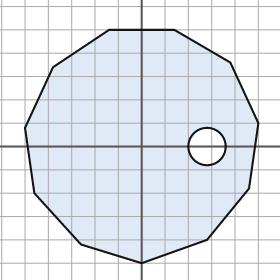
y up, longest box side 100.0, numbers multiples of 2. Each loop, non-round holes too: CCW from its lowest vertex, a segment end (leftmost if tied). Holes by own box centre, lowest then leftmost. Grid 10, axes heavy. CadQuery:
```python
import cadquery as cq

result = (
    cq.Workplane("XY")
    .moveTo(0.0, -50.0)
    .lineTo(28.0, -40.0)
    .lineTo(46.0, -18.0)
    .lineTo(50.0, 10.0)
    .lineTo(38.0, 36.0)
    .lineTo(14.0, 50.0)
    .lineTo(-14.0, 50.0)
    .lineTo(-38.0, 34.0)
    .lineTo(-50.0, 8.0)
    .lineTo(-46.0, -20.0)
    .lineTo(-26.0, -42.0)
    .close()
    .moveTo(28.0, 0.0)
    .circle(8.0)
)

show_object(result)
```